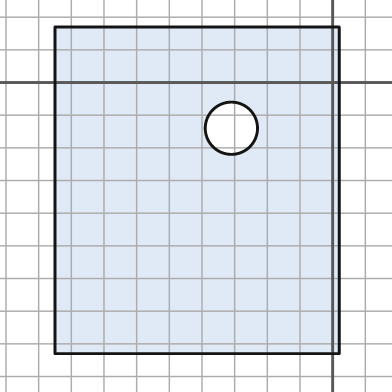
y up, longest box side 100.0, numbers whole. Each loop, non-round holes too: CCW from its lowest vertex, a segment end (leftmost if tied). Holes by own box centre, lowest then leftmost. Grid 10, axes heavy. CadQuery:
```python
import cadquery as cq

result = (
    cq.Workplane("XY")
    .moveTo(-85.0, -83.0)
    .lineTo(2.0, -83.0)
    .lineTo(2.0, 17.0)
    .lineTo(-85.0, 17.0)
    .close()
    .moveTo(-31.0, -14.0)
    .circle(8.0)
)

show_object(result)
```